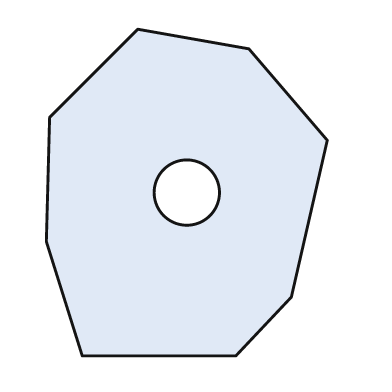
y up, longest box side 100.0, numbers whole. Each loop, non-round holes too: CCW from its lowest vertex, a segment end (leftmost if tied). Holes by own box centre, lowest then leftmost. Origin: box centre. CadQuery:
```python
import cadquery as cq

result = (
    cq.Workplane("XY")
    .moveTo(-32.0, -50.0)
    .lineTo(15.0, -50.0)
    .lineTo(32.0, -32.0)
    .lineTo(43.0, 16.0)
    .lineTo(19.0, 44.0)
    .lineTo(-15.0, 50.0)
    .lineTo(-42.0, 23.0)
    .lineTo(-43.0, -15.0)
    .close()
    .moveTo(0.0, 0.0)
    .circle(10.0)
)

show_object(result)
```